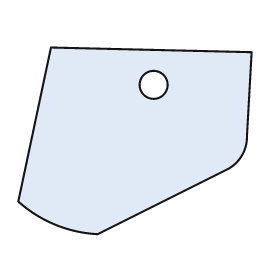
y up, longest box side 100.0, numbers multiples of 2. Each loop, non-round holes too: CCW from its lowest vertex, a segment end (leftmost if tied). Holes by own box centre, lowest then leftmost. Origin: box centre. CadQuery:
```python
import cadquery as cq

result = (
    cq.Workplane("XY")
    .moveTo(-16.0, -40.0)
    .lineTo(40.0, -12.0)
    .threePointArc((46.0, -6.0), (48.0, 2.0))
    .lineTo(50.0, 38.0)
    .lineTo(-36.0, 40.0)
    .lineTo(-50.0, -26.0)
    .threePointArc((-34.0, -36.0), (-16.0, -40.0))
    .close()
    .moveTo(8.0, 24.0)
    .circle(6.0)
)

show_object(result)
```